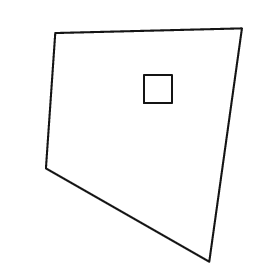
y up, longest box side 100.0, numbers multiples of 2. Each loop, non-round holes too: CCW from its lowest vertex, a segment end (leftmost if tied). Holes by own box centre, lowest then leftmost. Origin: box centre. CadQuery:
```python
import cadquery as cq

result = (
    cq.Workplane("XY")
    .moveTo(28.0, -50.0)
    .lineTo(42.0, 50.0)
    .lineTo(-38.0, 48.0)
    .lineTo(-42.0, -10.0)
    .close()
    .moveTo(0.0, 18.0)
    .lineTo(12.0, 18.0)
    .lineTo(12.0, 30.0)
    .lineTo(0.0, 30.0)
    .close()
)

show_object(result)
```